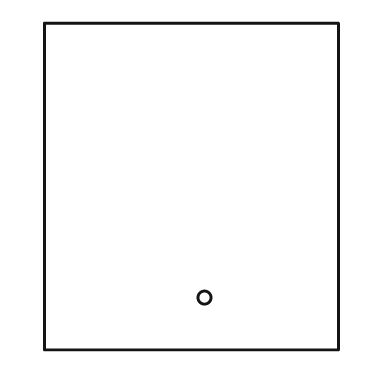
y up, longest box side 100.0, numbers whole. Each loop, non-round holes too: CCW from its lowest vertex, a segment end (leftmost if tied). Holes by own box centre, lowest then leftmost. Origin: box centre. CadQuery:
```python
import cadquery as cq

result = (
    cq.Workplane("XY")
    .moveTo(-45.0, -50.0)
    .lineTo(45.0, -50.0)
    .lineTo(45.0, 50.0)
    .lineTo(-45.0, 50.0)
    .close()
    .moveTo(4.0, -34.0)
    .circle(2.0)
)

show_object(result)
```